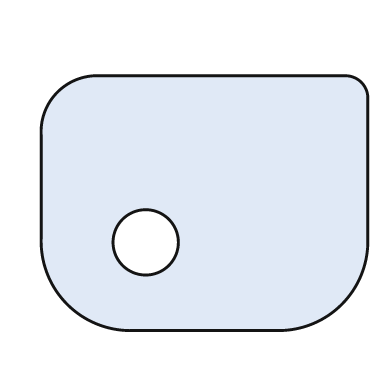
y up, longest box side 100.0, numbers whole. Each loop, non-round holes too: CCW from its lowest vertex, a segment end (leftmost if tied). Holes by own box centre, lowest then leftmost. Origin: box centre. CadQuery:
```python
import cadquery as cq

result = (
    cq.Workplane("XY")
    .moveTo(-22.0, -39.0)
    .lineTo(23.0, -39.0)
    .threePointArc((42.0, -31.0), (50.0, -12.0))
    .lineTo(50.0, 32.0)
    .threePointArc((48.0, 37.0), (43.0, 39.0))
    .lineTo(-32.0, 39.0)
    .threePointArc((-45.0, 34.0), (-50.0, 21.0))
    .lineTo(-50.0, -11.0)
    .threePointArc((-42.0, -31.0), (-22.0, -39.0))
    .close()
    .moveTo(-18.0, -12.0)
    .circle(10.0)
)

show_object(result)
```